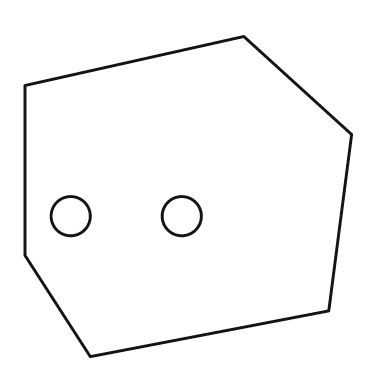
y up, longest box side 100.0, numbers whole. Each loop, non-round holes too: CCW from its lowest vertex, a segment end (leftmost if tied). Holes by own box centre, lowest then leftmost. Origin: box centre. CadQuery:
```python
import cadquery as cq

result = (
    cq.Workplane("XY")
    .moveTo(-30.0, -49.0)
    .lineTo(43.0, -35.0)
    .lineTo(50.0, 19.0)
    .lineTo(17.0, 49.0)
    .lineTo(-50.0, 34.0)
    .lineTo(-50.0, -18.0)
    .close()
    .moveTo(-36.0, -6.0)
    .circle(6.0)
    .moveTo(-2.0, -6.0)
    .circle(6.0)
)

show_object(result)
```